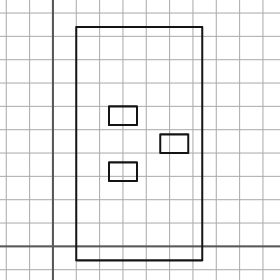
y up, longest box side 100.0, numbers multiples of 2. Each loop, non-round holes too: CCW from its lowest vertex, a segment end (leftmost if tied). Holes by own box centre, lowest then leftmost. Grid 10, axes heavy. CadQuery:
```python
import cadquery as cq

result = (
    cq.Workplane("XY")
    .moveTo(10.0, -6.0)
    .lineTo(64.0, -6.0)
    .lineTo(64.0, 94.0)
    .lineTo(10.0, 94.0)
    .close()
    .moveTo(24.0, 28.0)
    .lineTo(36.0, 28.0)
    .lineTo(36.0, 36.0)
    .lineTo(24.0, 36.0)
    .close()
    .moveTo(46.0, 40.0)
    .lineTo(58.0, 40.0)
    .lineTo(58.0, 48.0)
    .lineTo(46.0, 48.0)
    .close()
    .moveTo(24.0, 52.0)
    .lineTo(36.0, 52.0)
    .lineTo(36.0, 60.0)
    .lineTo(24.0, 60.0)
    .close()
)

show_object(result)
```